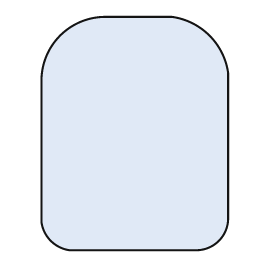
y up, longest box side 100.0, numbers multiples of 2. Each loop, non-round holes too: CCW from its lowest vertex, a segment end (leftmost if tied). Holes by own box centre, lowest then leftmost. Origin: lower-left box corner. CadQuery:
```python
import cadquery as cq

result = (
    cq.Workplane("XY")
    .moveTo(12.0, 0.0)
    .lineTo(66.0, 0.0)
    .threePointArc((76.0, 4.0), (80.0, 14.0))
    .lineTo(80.0, 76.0)
    .threePointArc((72.0, 92.0), (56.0, 100.0))
    .lineTo(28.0, 100.0)
    .threePointArc((8.0, 92.0), (0.0, 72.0))
    .lineTo(0.0, 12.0)
    .threePointArc((4.0, 4.0), (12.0, 0.0))
    .close()
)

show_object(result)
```